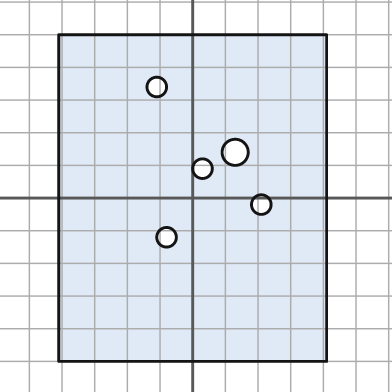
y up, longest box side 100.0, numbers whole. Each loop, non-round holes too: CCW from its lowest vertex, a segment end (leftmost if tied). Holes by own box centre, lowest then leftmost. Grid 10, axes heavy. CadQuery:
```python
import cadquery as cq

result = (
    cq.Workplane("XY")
    .moveTo(-41.0, -50.0)
    .lineTo(41.0, -50.0)
    .lineTo(41.0, 50.0)
    .lineTo(-41.0, 50.0)
    .close()
    .moveTo(-8.0, -12.0)
    .circle(3.0)
    .moveTo(21.0, -2.0)
    .circle(3.0)
    .moveTo(3.0, 9.0)
    .circle(3.0)
    .moveTo(13.0, 14.0)
    .circle(4.0)
    .moveTo(-11.0, 34.0)
    .circle(3.0)
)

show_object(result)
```